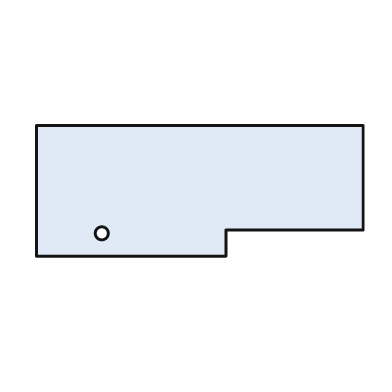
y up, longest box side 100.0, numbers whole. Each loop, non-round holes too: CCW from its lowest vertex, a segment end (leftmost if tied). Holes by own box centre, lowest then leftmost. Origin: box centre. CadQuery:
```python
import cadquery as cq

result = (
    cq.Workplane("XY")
    .moveTo(-50.0, -20.0)
    .lineTo(8.0, -20.0)
    .lineTo(8.0, -12.0)
    .lineTo(50.0, -12.0)
    .lineTo(50.0, 20.0)
    .lineTo(-50.0, 20.0)
    .close()
    .moveTo(-30.0, -13.0)
    .circle(2.0)
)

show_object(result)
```